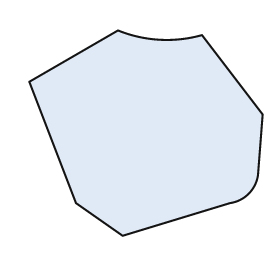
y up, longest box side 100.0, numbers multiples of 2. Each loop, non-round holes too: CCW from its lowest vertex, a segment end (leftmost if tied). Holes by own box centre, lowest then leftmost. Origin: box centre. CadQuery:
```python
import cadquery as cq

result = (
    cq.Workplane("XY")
    .moveTo(-10.0, -44.0)
    .lineTo(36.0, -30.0)
    .threePointArc((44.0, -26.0), (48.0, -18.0))
    .lineTo(50.0, 8.0)
    .lineTo(24.0, 42.0)
    .threePointArc((6.0, 40.0), (-12.0, 44.0))
    .lineTo(-50.0, 22.0)
    .lineTo(-30.0, -30.0)
    .close()
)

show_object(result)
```